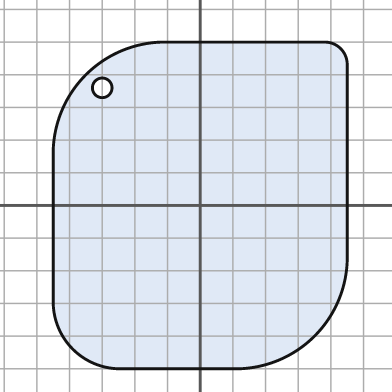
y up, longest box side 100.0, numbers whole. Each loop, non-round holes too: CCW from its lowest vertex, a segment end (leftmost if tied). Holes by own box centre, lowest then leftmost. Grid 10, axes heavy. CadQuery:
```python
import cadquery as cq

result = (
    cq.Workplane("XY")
    .moveTo(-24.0, -50.0)
    .lineTo(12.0, -50.0)
    .threePointArc((35.0, -40.0), (45.0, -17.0))
    .lineTo(45.0, 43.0)
    .threePointArc((43.0, 48.0), (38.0, 50.0))
    .lineTo(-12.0, 50.0)
    .threePointArc((-35.0, 40.0), (-45.0, 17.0))
    .lineTo(-45.0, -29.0)
    .threePointArc((-39.0, -44.0), (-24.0, -50.0))
    .close()
    .moveTo(-30.0, 36.0)
    .circle(3.0)
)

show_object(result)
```